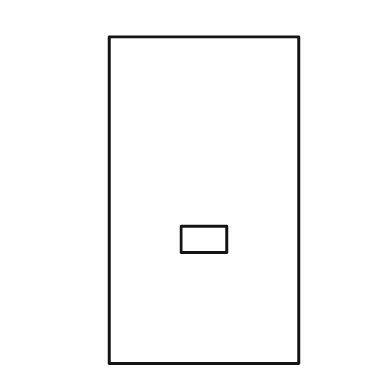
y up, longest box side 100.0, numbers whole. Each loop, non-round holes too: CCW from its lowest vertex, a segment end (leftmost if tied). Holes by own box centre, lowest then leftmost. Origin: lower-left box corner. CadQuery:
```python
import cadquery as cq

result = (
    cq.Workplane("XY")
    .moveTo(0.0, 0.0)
    .lineTo(58.0, 0.0)
    .lineTo(58.0, 100.0)
    .lineTo(0.0, 100.0)
    .close()
    .moveTo(22.0, 34.0)
    .lineTo(36.0, 34.0)
    .lineTo(36.0, 42.0)
    .lineTo(22.0, 42.0)
    .close()
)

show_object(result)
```